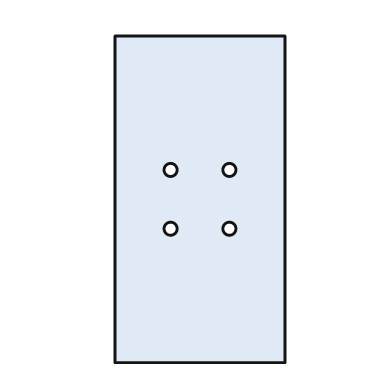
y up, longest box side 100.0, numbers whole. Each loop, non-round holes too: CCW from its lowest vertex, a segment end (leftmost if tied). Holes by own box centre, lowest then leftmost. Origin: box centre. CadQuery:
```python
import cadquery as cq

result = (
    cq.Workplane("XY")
    .moveTo(-26.0, -50.0)
    .lineTo(26.0, -50.0)
    .lineTo(26.0, 50.0)
    .lineTo(-26.0, 50.0)
    .close()
    .moveTo(-9.0, -9.0)
    .circle(2.0)
    .moveTo(9.0, -9.0)
    .circle(2.0)
    .moveTo(-9.0, 9.0)
    .circle(2.0)
    .moveTo(9.0, 9.0)
    .circle(2.0)
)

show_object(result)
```